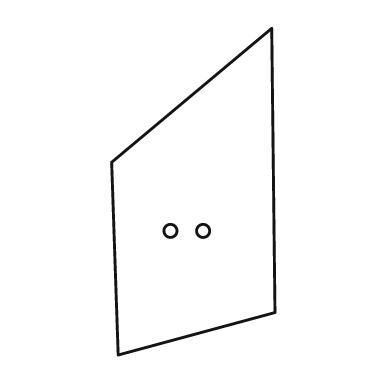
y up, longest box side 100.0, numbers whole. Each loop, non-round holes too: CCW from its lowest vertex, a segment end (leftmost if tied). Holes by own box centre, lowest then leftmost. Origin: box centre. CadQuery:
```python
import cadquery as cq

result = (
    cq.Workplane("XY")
    .moveTo(-23.0, -50.0)
    .lineTo(25.0, -37.0)
    .lineTo(24.0, 50.0)
    .lineTo(-25.0, 9.0)
    .close()
    .moveTo(-7.0, -12.0)
    .circle(2.0)
    .moveTo(3.0, -12.0)
    .circle(2.0)
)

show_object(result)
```